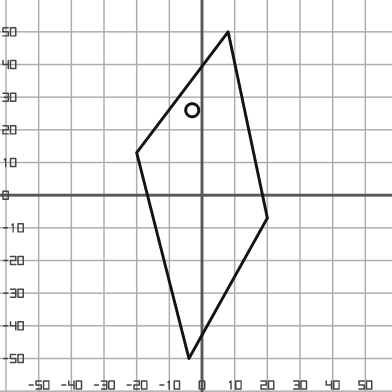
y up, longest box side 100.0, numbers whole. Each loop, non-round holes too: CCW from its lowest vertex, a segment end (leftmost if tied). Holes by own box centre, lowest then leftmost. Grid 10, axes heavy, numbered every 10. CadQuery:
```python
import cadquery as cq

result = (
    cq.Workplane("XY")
    .moveTo(-4.0, -50.0)
    .lineTo(20.0, -7.0)
    .lineTo(8.0, 50.0)
    .lineTo(-20.0, 13.0)
    .close()
    .moveTo(-3.0, 26.0)
    .circle(2.0)
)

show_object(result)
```